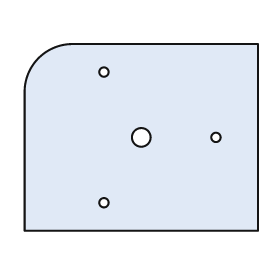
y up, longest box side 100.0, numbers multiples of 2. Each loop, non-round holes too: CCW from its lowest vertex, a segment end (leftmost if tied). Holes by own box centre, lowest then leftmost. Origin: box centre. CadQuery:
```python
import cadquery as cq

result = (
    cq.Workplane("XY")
    .moveTo(-50.0, -40.0)
    .lineTo(50.0, -40.0)
    .lineTo(50.0, 40.0)
    .lineTo(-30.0, 40.0)
    .threePointArc((-44.0, 34.0), (-50.0, 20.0))
    .close()
    .moveTo(-16.0, -28.0)
    .circle(2.0)
    .moveTo(0.0, 0.0)
    .circle(4.0)
    .moveTo(32.0, 0.0)
    .circle(2.0)
    .moveTo(-16.0, 28.0)
    .circle(2.0)
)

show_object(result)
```